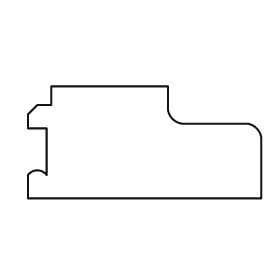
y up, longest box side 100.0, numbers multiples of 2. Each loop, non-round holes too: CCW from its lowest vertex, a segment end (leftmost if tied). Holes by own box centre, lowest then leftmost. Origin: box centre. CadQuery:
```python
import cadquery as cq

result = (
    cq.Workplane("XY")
    .moveTo(-50.0, -24.0)
    .lineTo(50.0, -24.0)
    .lineTo(50.0, 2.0)
    .threePointArc((48.0, 6.0), (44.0, 8.0))
    .lineTo(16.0, 8.0)
    .threePointArc((12.0, 10.0), (10.0, 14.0))
    .lineTo(10.0, 24.0)
    .lineTo(-40.0, 24.0)
    .lineTo(-40.0, 16.0)
    .lineTo(-46.0, 16.0)
    .lineTo(-50.0, 12.0)
    .lineTo(-50.0, 6.0)
    .lineTo(-42.0, 6.0)
    .lineTo(-42.0, -14.0)
    .threePointArc((-46.0, -12.0), (-50.0, -14.0))
    .close()
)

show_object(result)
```